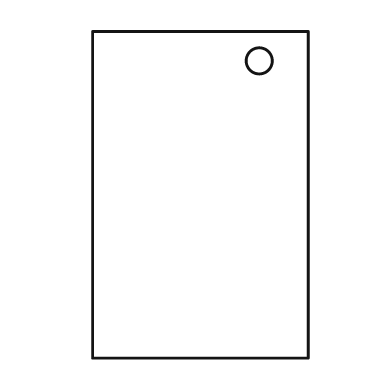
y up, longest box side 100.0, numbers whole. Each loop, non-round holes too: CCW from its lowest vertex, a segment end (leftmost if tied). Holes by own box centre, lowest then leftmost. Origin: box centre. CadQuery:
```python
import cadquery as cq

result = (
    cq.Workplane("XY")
    .moveTo(-33.0, -50.0)
    .lineTo(33.0, -50.0)
    .lineTo(33.0, 50.0)
    .lineTo(-33.0, 50.0)
    .close()
    .moveTo(18.0, 41.0)
    .circle(4.0)
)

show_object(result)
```